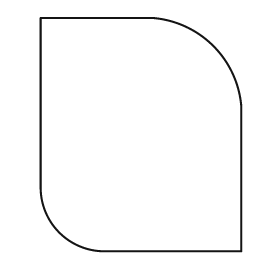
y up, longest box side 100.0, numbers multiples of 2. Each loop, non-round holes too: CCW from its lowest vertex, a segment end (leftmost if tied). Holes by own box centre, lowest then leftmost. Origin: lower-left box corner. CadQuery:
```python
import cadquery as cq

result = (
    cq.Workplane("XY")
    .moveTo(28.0, 0.0)
    .lineTo(86.0, 0.0)
    .lineTo(86.0, 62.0)
    .threePointArc((74.0, 88.0), (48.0, 100.0))
    .lineTo(0.0, 100.0)
    .lineTo(0.0, 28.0)
    .threePointArc((8.0, 8.0), (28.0, 0.0))
    .close()
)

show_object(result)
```